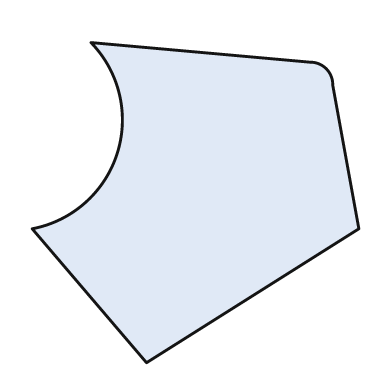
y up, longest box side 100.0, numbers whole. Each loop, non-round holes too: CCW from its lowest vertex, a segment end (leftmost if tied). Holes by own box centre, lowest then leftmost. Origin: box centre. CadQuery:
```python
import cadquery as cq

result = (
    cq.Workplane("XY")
    .moveTo(-15.0, -49.0)
    .lineTo(50.0, -8.0)
    .lineTo(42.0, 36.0)
    .threePointArc((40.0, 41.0), (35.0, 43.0))
    .lineTo(-32.0, 49.0)
    .threePointArc((-24.0, 15.0), (-50.0, -8.0))
    .close()
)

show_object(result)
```